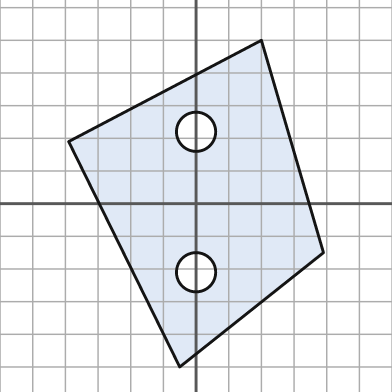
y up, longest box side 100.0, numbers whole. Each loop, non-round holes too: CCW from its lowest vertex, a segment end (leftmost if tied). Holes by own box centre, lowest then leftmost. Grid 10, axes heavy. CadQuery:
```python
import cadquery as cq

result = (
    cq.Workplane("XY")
    .moveTo(-5.0, -50.0)
    .lineTo(39.0, -15.0)
    .lineTo(20.0, 50.0)
    .lineTo(-39.0, 19.0)
    .close()
    .moveTo(0.0, -21.0)
    .circle(6.0)
    .moveTo(0.0, 22.0)
    .circle(6.0)
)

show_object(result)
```